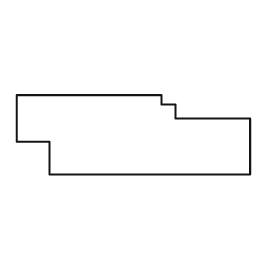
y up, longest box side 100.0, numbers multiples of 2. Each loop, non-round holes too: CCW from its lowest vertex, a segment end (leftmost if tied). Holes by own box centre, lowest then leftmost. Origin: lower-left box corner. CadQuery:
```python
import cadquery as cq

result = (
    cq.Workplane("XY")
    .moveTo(14.0, 0.0)
    .lineTo(100.0, 0.0)
    .lineTo(100.0, 24.0)
    .lineTo(68.0, 24.0)
    .lineTo(68.0, 30.0)
    .lineTo(62.0, 30.0)
    .lineTo(62.0, 34.0)
    .lineTo(0.0, 34.0)
    .lineTo(0.0, 14.0)
    .lineTo(14.0, 14.0)
    .close()
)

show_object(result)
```